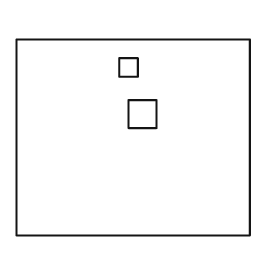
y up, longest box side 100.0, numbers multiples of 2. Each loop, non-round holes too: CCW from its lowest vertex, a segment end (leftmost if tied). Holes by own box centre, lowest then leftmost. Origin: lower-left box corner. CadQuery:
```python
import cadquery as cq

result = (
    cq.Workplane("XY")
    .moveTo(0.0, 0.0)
    .lineTo(100.0, 0.0)
    .lineTo(100.0, 84.0)
    .lineTo(0.0, 84.0)
    .close()
    .moveTo(48.0, 46.0)
    .lineTo(60.0, 46.0)
    .lineTo(60.0, 58.0)
    .lineTo(48.0, 58.0)
    .close()
    .moveTo(44.0, 68.0)
    .lineTo(52.0, 68.0)
    .lineTo(52.0, 76.0)
    .lineTo(44.0, 76.0)
    .close()
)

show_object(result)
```